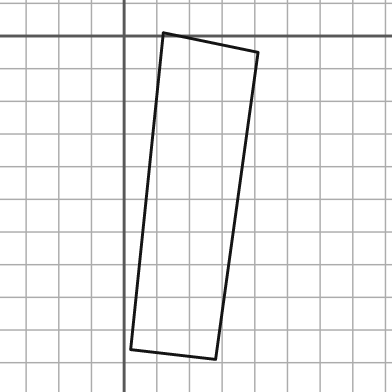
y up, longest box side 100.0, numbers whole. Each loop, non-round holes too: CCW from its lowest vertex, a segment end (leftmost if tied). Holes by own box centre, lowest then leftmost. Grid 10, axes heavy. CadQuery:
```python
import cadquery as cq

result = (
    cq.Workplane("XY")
    .moveTo(28.0, -99.0)
    .lineTo(41.0, -5.0)
    .lineTo(12.0, 1.0)
    .lineTo(2.0, -96.0)
    .close()
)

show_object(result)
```